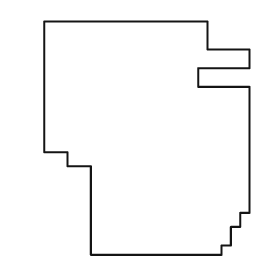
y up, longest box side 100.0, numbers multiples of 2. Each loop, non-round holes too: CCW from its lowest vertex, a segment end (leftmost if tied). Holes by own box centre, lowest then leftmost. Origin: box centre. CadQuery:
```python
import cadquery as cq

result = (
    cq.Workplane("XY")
    .moveTo(-24.0, -50.0)
    .lineTo(32.0, -50.0)
    .lineTo(32.0, -46.0)
    .lineTo(36.0, -46.0)
    .lineTo(36.0, -38.0)
    .lineTo(40.0, -38.0)
    .lineTo(40.0, -32.0)
    .lineTo(44.0, -32.0)
    .lineTo(44.0, 22.0)
    .lineTo(22.0, 22.0)
    .lineTo(22.0, 30.0)
    .lineTo(44.0, 30.0)
    .lineTo(44.0, 38.0)
    .lineTo(26.0, 38.0)
    .lineTo(26.0, 50.0)
    .lineTo(-44.0, 50.0)
    .lineTo(-44.0, -6.0)
    .lineTo(-34.0, -6.0)
    .lineTo(-34.0, -12.0)
    .lineTo(-24.0, -12.0)
    .close()
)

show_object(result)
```